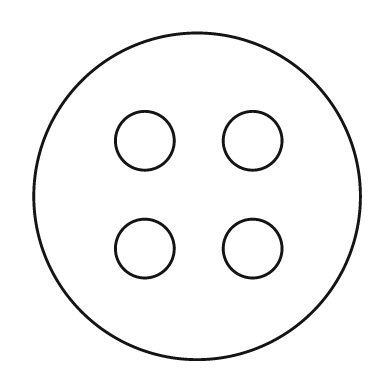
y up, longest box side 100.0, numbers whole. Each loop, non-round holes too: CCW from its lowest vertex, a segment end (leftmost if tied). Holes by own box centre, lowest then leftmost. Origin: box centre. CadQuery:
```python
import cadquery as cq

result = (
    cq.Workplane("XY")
    .moveTo(0.0, 0.0)
    .circle(50.0)
    .moveTo(-16.0, -16.0)
    .circle(9.0)
    .moveTo(17.0, -16.0)
    .circle(9.0)
    .moveTo(-16.0, 17.0)
    .circle(9.0)
    .moveTo(17.0, 17.0)
    .circle(9.0)
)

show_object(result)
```